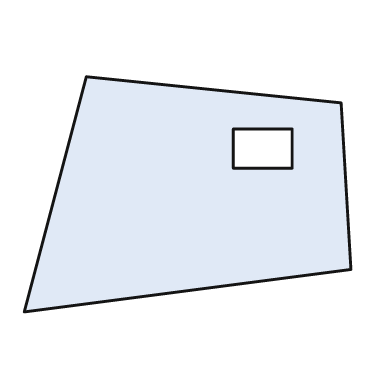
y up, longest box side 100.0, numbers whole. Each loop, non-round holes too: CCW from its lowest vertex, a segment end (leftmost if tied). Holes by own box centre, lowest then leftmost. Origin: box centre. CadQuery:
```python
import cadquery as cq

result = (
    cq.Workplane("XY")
    .moveTo(-50.0, -36.0)
    .lineTo(50.0, -23.0)
    .lineTo(47.0, 28.0)
    .lineTo(-31.0, 36.0)
    .close()
    .moveTo(14.0, 8.0)
    .lineTo(32.0, 8.0)
    .lineTo(32.0, 20.0)
    .lineTo(14.0, 20.0)
    .close()
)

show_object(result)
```